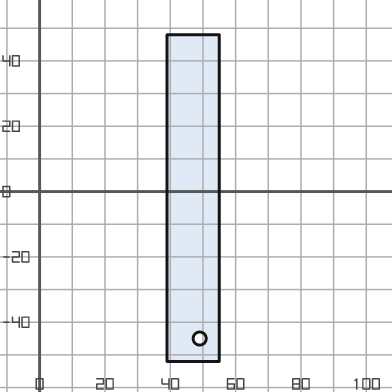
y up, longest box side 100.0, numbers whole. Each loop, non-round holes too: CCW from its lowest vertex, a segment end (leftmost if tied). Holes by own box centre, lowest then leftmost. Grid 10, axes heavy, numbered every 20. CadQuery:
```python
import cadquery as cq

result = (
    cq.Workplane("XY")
    .moveTo(39.0, -52.0)
    .lineTo(55.0, -52.0)
    .lineTo(55.0, 48.0)
    .lineTo(39.0, 48.0)
    .close()
    .moveTo(49.0, -45.0)
    .circle(2.0)
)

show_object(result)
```